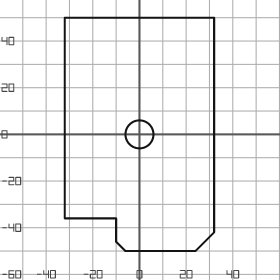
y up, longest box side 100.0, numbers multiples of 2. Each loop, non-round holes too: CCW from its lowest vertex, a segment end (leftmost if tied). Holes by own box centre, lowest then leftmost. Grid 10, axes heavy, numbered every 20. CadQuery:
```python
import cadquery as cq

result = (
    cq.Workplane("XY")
    .moveTo(-6.0, -50.0)
    .lineTo(24.0, -50.0)
    .lineTo(32.0, -42.0)
    .lineTo(32.0, 50.0)
    .lineTo(-32.0, 50.0)
    .lineTo(-32.0, -36.0)
    .lineTo(-10.0, -36.0)
    .lineTo(-10.0, -46.0)
    .close()
    .moveTo(0.0, 0.0)
    .circle(6.0)
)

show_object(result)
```